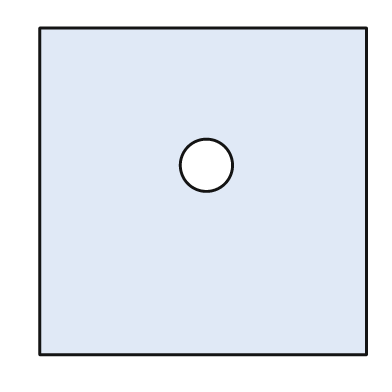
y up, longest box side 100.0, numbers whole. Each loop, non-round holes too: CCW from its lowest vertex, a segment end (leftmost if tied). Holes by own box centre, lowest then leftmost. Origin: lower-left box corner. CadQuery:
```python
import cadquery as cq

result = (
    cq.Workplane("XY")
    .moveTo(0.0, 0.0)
    .lineTo(100.0, 0.0)
    .lineTo(100.0, 100.0)
    .lineTo(0.0, 100.0)
    .close()
    .moveTo(51.0, 58.0)
    .circle(8.0)
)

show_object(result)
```